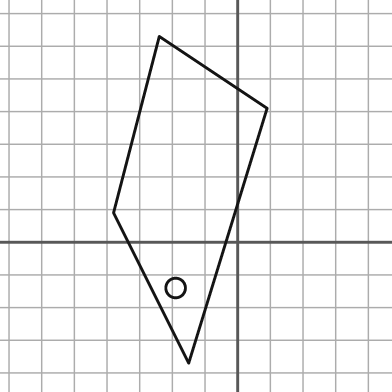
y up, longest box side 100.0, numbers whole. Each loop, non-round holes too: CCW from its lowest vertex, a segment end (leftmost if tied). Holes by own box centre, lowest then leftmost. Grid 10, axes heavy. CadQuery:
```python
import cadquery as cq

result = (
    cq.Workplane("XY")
    .moveTo(-15.0, -37.0)
    .lineTo(9.0, 41.0)
    .lineTo(-24.0, 63.0)
    .lineTo(-38.0, 9.0)
    .close()
    .moveTo(-19.0, -14.0)
    .circle(3.0)
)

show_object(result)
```